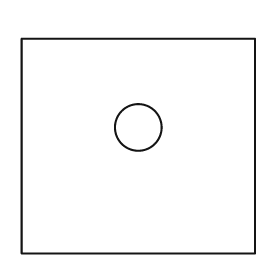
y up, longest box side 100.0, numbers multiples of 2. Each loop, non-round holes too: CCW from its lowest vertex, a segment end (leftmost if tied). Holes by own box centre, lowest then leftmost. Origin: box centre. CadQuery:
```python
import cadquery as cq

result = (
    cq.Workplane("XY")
    .moveTo(-50.0, -46.0)
    .lineTo(50.0, -46.0)
    .lineTo(50.0, 46.0)
    .lineTo(-50.0, 46.0)
    .close()
    .moveTo(0.0, 8.0)
    .circle(10.0)
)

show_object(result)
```